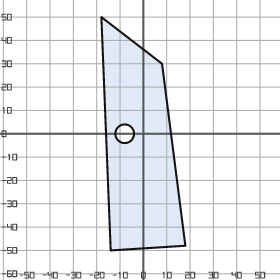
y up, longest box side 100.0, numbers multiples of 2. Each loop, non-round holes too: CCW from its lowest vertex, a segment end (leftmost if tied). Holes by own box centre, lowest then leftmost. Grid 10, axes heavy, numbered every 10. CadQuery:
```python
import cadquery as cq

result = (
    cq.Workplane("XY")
    .moveTo(-14.0, -50.0)
    .lineTo(18.0, -48.0)
    .lineTo(8.0, 30.0)
    .lineTo(-18.0, 50.0)
    .close()
    .moveTo(-8.0, 0.0)
    .circle(4.0)
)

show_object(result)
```